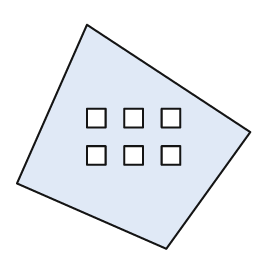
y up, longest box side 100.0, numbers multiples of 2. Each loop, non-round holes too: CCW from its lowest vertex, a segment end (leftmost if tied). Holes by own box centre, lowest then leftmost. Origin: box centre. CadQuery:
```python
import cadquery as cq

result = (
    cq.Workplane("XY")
    .moveTo(14.0, -48.0)
    .lineTo(50.0, 2.0)
    .lineTo(-20.0, 48.0)
    .lineTo(-50.0, -20.0)
    .close()
    .moveTo(-20.0, -12.0)
    .lineTo(-12.0, -12.0)
    .lineTo(-12.0, -4.0)
    .lineTo(-20.0, -4.0)
    .close()
    .moveTo(-4.0, -12.0)
    .lineTo(4.0, -12.0)
    .lineTo(4.0, -4.0)
    .lineTo(-4.0, -4.0)
    .close()
    .moveTo(12.0, -12.0)
    .lineTo(20.0, -12.0)
    .lineTo(20.0, -4.0)
    .lineTo(12.0, -4.0)
    .close()
    .moveTo(-20.0, 4.0)
    .lineTo(-12.0, 4.0)
    .lineTo(-12.0, 12.0)
    .lineTo(-20.0, 12.0)
    .close()
    .moveTo(-4.0, 4.0)
    .lineTo(4.0, 4.0)
    .lineTo(4.0, 12.0)
    .lineTo(-4.0, 12.0)
    .close()
    .moveTo(12.0, 4.0)
    .lineTo(20.0, 4.0)
    .lineTo(20.0, 12.0)
    .lineTo(12.0, 12.0)
    .close()
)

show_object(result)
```